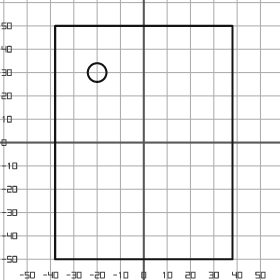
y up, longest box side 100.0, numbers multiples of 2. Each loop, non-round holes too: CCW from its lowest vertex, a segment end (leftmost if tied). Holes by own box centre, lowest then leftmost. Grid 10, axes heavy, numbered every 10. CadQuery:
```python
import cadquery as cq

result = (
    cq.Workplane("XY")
    .moveTo(-38.0, -50.0)
    .lineTo(38.0, -50.0)
    .lineTo(38.0, 50.0)
    .lineTo(-38.0, 50.0)
    .close()
    .moveTo(-20.0, 30.0)
    .circle(4.0)
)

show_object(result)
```